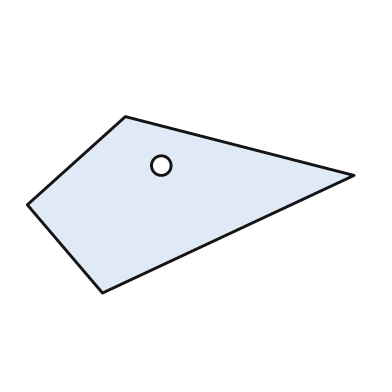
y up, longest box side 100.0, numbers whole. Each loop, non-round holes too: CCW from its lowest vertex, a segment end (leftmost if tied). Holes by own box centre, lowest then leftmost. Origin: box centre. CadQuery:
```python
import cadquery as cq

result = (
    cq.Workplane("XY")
    .moveTo(-27.0, -27.0)
    .lineTo(50.0, 9.0)
    .lineTo(-20.0, 27.0)
    .lineTo(-50.0, 0.0)
    .close()
    .moveTo(-9.0, 12.0)
    .circle(3.0)
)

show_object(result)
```